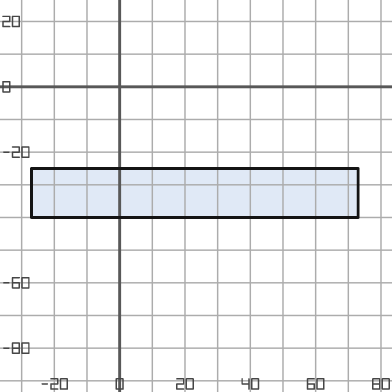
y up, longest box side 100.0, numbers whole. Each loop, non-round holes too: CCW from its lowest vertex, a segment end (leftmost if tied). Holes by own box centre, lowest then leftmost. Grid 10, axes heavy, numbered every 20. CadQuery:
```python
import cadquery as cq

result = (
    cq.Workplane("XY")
    .moveTo(-27.0, -40.0)
    .lineTo(73.0, -40.0)
    .lineTo(73.0, -25.0)
    .lineTo(-27.0, -25.0)
    .close()
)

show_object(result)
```